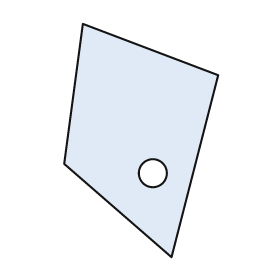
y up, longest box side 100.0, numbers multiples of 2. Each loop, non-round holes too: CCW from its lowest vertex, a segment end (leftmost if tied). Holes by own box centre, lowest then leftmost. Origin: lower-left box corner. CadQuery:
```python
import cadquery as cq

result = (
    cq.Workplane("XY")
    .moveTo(46.0, 0.0)
    .lineTo(66.0, 78.0)
    .lineTo(8.0, 100.0)
    .lineTo(0.0, 40.0)
    .close()
    .moveTo(38.0, 36.0)
    .circle(6.0)
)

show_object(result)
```